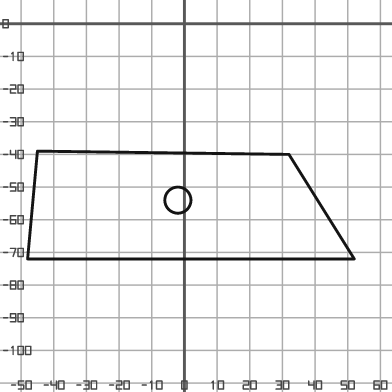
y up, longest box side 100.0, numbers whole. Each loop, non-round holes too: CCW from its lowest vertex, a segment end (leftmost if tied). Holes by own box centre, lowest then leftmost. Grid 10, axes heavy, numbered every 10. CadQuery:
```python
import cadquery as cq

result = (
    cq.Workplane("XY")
    .moveTo(-48.0, -72.0)
    .lineTo(52.0, -72.0)
    .lineTo(32.0, -40.0)
    .lineTo(-45.0, -39.0)
    .close()
    .moveTo(-2.0, -54.0)
    .circle(4.0)
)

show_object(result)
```